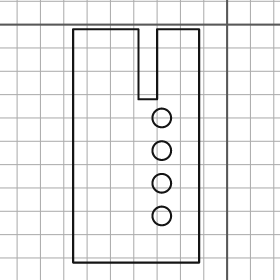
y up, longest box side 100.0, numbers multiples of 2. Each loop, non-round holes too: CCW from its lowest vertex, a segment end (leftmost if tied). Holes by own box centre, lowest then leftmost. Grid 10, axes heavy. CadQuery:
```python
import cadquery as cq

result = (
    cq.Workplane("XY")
    .moveTo(-66.0, -102.0)
    .lineTo(-12.0, -102.0)
    .lineTo(-12.0, -2.0)
    .lineTo(-30.0, -2.0)
    .lineTo(-30.0, -32.0)
    .lineTo(-38.0, -32.0)
    .lineTo(-38.0, -2.0)
    .lineTo(-66.0, -2.0)
    .close()
    .moveTo(-28.0, -82.0)
    .circle(4.0)
    .moveTo(-28.0, -68.0)
    .circle(4.0)
    .moveTo(-28.0, -54.0)
    .circle(4.0)
    .moveTo(-28.0, -40.0)
    .circle(4.0)
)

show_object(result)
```